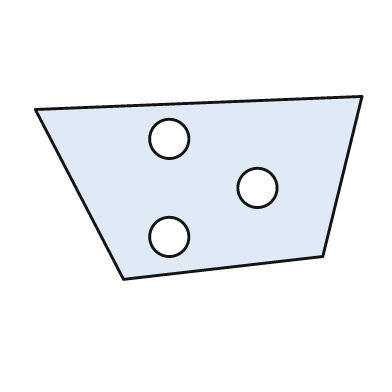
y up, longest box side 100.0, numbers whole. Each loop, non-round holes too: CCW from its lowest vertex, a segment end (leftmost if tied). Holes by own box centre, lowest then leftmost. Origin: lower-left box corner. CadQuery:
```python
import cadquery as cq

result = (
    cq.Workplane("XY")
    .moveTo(27.0, 0.0)
    .lineTo(88.0, 7.0)
    .lineTo(100.0, 56.0)
    .lineTo(0.0, 52.0)
    .close()
    .moveTo(41.0, 13.0)
    .circle(6.0)
    .moveTo(68.0, 28.0)
    .circle(6.0)
    .moveTo(41.0, 43.0)
    .circle(6.0)
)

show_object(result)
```